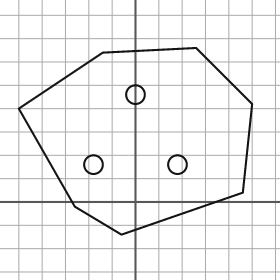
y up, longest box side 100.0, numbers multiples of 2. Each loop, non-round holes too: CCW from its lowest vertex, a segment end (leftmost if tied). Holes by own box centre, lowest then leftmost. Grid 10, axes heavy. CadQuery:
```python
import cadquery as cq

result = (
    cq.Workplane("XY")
    .moveTo(-6.0, -14.0)
    .lineTo(46.0, 4.0)
    .lineTo(50.0, 42.0)
    .lineTo(26.0, 66.0)
    .lineTo(-14.0, 64.0)
    .lineTo(-50.0, 40.0)
    .lineTo(-26.0, -2.0)
    .close()
    .moveTo(-18.0, 16.0)
    .circle(4.0)
    .moveTo(18.0, 16.0)
    .circle(4.0)
    .moveTo(0.0, 46.0)
    .circle(4.0)
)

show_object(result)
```